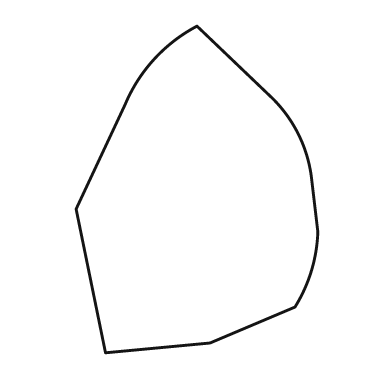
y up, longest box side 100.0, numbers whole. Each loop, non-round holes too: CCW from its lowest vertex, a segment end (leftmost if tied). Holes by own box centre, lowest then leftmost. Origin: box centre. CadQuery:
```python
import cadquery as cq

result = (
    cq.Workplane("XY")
    .moveTo(-28.0, -50.0)
    .lineTo(4.0, -47.0)
    .lineTo(30.0, -36.0)
    .threePointArc((35.0, -25.0), (37.0, -13.0))
    .lineTo(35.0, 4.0)
    .threePointArc((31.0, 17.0), (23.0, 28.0))
    .lineTo(0.0, 50.0)
    .threePointArc((-13.0, 40.0), (-22.0, 26.0))
    .lineTo(-37.0, -6.0)
    .close()
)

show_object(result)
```